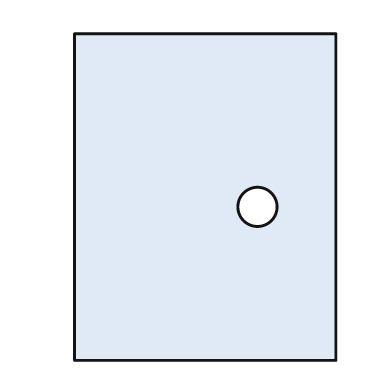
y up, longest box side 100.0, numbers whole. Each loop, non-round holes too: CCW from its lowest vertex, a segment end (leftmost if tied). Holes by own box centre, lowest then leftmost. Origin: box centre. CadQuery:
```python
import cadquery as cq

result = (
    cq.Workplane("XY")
    .moveTo(-40.0, -50.0)
    .lineTo(40.0, -50.0)
    .lineTo(40.0, 50.0)
    .lineTo(-40.0, 50.0)
    .close()
    .moveTo(16.0, -3.0)
    .circle(6.0)
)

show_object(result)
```